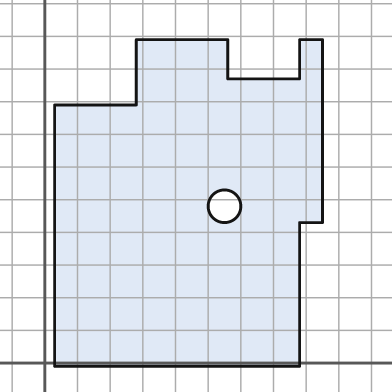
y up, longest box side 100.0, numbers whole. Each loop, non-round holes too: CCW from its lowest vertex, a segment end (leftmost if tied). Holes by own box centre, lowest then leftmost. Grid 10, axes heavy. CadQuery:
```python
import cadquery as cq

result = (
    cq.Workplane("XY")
    .moveTo(3.0, -1.0)
    .lineTo(78.0, -1.0)
    .lineTo(78.0, 43.0)
    .lineTo(85.0, 43.0)
    .lineTo(85.0, 99.0)
    .lineTo(78.0, 99.0)
    .lineTo(78.0, 87.0)
    .lineTo(56.0, 87.0)
    .lineTo(56.0, 99.0)
    .lineTo(28.0, 99.0)
    .lineTo(28.0, 79.0)
    .lineTo(3.0, 79.0)
    .close()
    .moveTo(55.0, 48.0)
    .circle(5.0)
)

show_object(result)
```